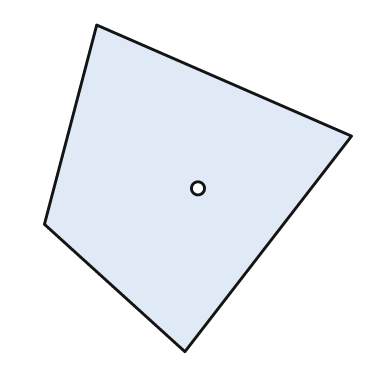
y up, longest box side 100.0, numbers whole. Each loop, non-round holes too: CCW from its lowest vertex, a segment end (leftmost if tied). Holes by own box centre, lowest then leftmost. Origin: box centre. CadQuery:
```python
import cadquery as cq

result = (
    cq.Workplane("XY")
    .moveTo(-4.0, -50.0)
    .lineTo(47.0, 16.0)
    .lineTo(-31.0, 50.0)
    .lineTo(-47.0, -11.0)
    .close()
    .moveTo(0.0, 0.0)
    .circle(2.0)
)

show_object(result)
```